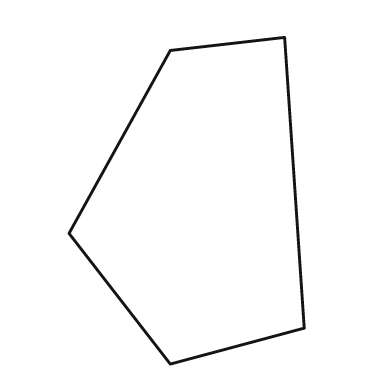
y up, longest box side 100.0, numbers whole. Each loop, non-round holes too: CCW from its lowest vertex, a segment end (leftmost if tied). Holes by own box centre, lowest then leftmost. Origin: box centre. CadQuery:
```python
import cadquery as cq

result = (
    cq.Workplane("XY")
    .moveTo(-5.0, -50.0)
    .lineTo(36.0, -39.0)
    .lineTo(30.0, 50.0)
    .lineTo(-5.0, 46.0)
    .lineTo(-36.0, -10.0)
    .close()
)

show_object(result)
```